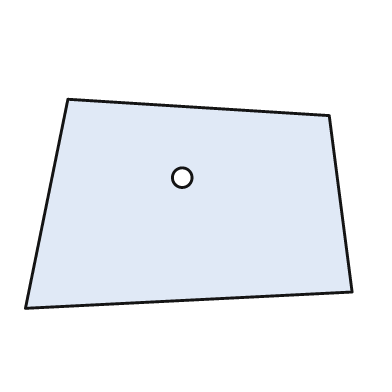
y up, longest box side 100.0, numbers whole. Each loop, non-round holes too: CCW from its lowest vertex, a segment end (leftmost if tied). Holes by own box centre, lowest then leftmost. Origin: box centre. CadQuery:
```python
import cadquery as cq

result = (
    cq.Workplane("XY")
    .moveTo(-50.0, -32.0)
    .lineTo(50.0, -27.0)
    .lineTo(43.0, 27.0)
    .lineTo(-37.0, 32.0)
    .close()
    .moveTo(-2.0, 8.0)
    .circle(3.0)
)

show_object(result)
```